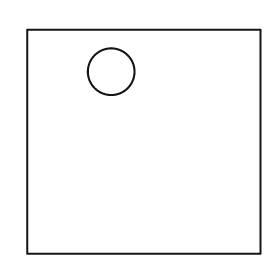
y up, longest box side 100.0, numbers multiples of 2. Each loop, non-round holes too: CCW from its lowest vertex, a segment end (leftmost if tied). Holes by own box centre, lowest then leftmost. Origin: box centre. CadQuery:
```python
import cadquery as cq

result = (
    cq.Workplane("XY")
    .moveTo(-50.0, -48.0)
    .lineTo(50.0, -48.0)
    .lineTo(50.0, 48.0)
    .lineTo(-50.0, 48.0)
    .close()
    .moveTo(-14.0, 30.0)
    .circle(10.0)
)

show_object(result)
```